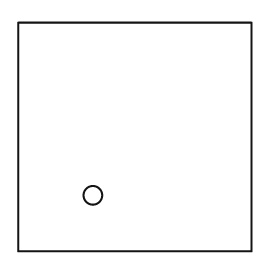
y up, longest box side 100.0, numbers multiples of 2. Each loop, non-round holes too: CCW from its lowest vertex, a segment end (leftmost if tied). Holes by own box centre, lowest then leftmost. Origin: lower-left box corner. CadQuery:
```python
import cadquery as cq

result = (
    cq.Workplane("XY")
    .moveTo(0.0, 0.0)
    .lineTo(100.0, 0.0)
    .lineTo(100.0, 98.0)
    .lineTo(0.0, 98.0)
    .close()
    .moveTo(32.0, 24.0)
    .circle(4.0)
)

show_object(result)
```